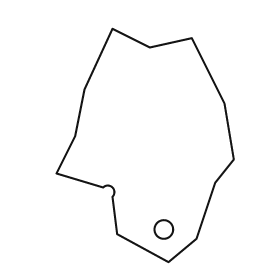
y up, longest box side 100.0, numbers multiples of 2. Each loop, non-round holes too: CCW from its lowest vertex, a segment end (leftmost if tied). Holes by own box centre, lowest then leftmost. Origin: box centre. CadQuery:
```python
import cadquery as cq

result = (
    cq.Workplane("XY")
    .moveTo(10.0, -50.0)
    .lineTo(22.0, -40.0)
    .lineTo(30.0, -16.0)
    .lineTo(38.0, -6.0)
    .lineTo(34.0, 18.0)
    .lineTo(20.0, 46.0)
    .lineTo(2.0, 42.0)
    .lineTo(-14.0, 50.0)
    .lineTo(-26.0, 24.0)
    .lineTo(-30.0, 4.0)
    .lineTo(-38.0, -12.0)
    .lineTo(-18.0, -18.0)
    .threePointArc((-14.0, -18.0), (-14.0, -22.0))
    .lineTo(-12.0, -38.0)
    .close()
    .moveTo(8.0, -36.0)
    .circle(4.0)
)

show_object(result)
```